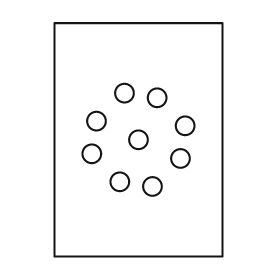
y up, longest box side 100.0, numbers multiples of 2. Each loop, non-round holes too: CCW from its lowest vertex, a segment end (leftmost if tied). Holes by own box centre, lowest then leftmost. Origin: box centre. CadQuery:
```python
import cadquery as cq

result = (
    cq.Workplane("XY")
    .moveTo(-36.0, -50.0)
    .lineTo(36.0, -50.0)
    .lineTo(36.0, 50.0)
    .lineTo(-36.0, 50.0)
    .close()
    .moveTo(6.0, -20.0)
    .circle(4.0)
    .moveTo(-8.0, -18.0)
    .circle(4.0)
    .moveTo(18.0, -8.0)
    .circle(4.0)
    .moveTo(-20.0, -6.0)
    .circle(4.0)
    .moveTo(0.0, 0.0)
    .circle(4.0)
    .moveTo(20.0, 6.0)
    .circle(4.0)
    .moveTo(-18.0, 8.0)
    .circle(4.0)
    .moveTo(8.0, 18.0)
    .circle(4.0)
    .moveTo(-6.0, 20.0)
    .circle(4.0)
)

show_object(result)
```